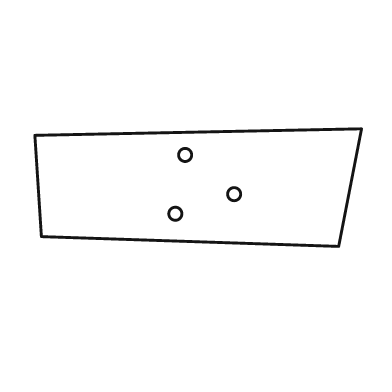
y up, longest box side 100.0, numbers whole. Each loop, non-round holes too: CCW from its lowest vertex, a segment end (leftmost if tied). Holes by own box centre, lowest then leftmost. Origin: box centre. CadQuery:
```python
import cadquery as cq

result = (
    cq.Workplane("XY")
    .moveTo(43.0, -18.0)
    .lineTo(50.0, 18.0)
    .lineTo(-50.0, 16.0)
    .lineTo(-48.0, -15.0)
    .close()
    .moveTo(-7.0, -8.0)
    .circle(2.0)
    .moveTo(11.0, -2.0)
    .circle(2.0)
    .moveTo(-4.0, 10.0)
    .circle(2.0)
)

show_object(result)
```